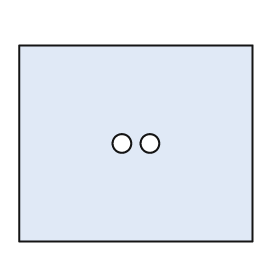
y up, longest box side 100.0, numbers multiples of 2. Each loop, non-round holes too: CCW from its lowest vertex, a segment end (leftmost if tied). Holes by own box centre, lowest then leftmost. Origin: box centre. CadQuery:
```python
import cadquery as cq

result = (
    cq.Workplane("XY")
    .moveTo(-50.0, -42.0)
    .lineTo(50.0, -42.0)
    .lineTo(50.0, 42.0)
    .lineTo(-50.0, 42.0)
    .close()
    .moveTo(-6.0, 0.0)
    .circle(4.0)
    .moveTo(6.0, 0.0)
    .circle(4.0)
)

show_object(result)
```